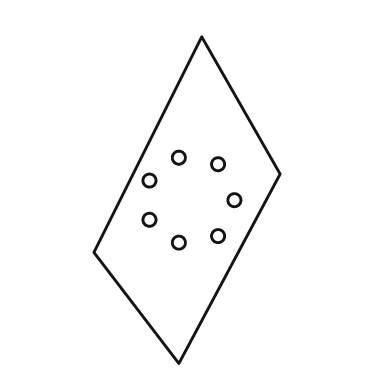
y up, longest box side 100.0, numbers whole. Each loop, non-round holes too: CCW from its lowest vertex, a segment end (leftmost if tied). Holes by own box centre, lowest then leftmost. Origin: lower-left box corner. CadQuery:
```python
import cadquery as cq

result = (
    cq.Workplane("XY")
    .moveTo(26.0, 0.0)
    .lineTo(57.0, 58.0)
    .lineTo(33.0, 100.0)
    .lineTo(0.0, 34.0)
    .close()
    .moveTo(26.0, 37.0)
    .circle(2.0)
    .moveTo(38.0, 39.0)
    .circle(2.0)
    .moveTo(17.0, 44.0)
    .circle(2.0)
    .moveTo(43.0, 50.0)
    .circle(2.0)
    .moveTo(17.0, 56.0)
    .circle(2.0)
    .moveTo(38.0, 61.0)
    .circle(2.0)
    .moveTo(26.0, 63.0)
    .circle(2.0)
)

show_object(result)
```